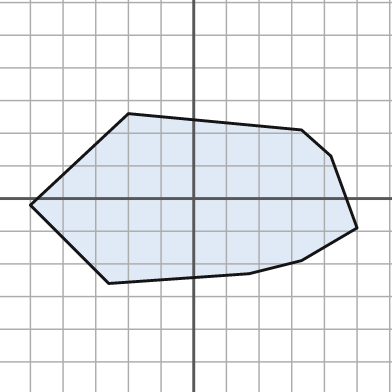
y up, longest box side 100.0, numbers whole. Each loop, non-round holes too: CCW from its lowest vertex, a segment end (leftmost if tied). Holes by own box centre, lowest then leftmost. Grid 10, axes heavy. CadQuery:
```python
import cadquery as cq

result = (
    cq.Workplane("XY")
    .moveTo(-26.0, -26.0)
    .lineTo(17.0, -23.0)
    .lineTo(33.0, -19.0)
    .lineTo(50.0, -9.0)
    .lineTo(42.0, 13.0)
    .lineTo(33.0, 21.0)
    .lineTo(-20.0, 26.0)
    .lineTo(-50.0, -2.0)
    .close()
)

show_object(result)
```